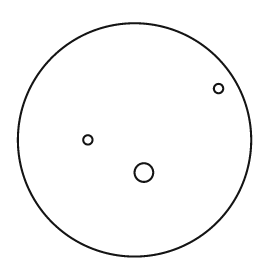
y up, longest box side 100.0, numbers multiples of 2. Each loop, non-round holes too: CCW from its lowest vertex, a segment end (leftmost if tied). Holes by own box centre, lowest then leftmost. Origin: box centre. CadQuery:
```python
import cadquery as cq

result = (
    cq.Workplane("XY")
    .moveTo(0.0, 0.0)
    .circle(50.0)
    .moveTo(4.0, -14.0)
    .circle(4.0)
    .moveTo(-20.0, 0.0)
    .circle(2.0)
    .moveTo(36.0, 22.0)
    .circle(2.0)
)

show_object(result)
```